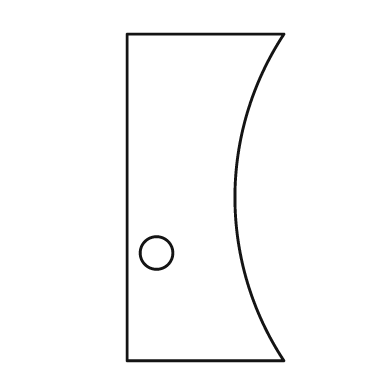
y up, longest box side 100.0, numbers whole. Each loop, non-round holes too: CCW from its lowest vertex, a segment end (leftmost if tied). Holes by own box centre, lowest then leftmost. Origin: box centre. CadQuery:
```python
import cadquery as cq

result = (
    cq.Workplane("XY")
    .moveTo(-24.0, -50.0)
    .lineTo(24.0, -50.0)
    .threePointArc((9.0, 0.0), (24.0, 50.0))
    .lineTo(-24.0, 50.0)
    .close()
    .moveTo(-15.0, -17.0)
    .circle(5.0)
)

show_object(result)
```